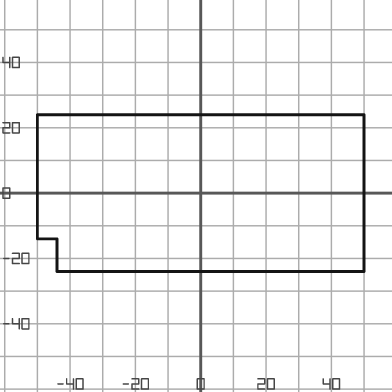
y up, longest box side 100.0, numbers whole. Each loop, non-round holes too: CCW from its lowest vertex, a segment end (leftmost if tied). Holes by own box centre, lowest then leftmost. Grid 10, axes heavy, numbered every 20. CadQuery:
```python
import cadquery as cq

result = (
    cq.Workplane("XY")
    .moveTo(-44.0, -24.0)
    .lineTo(50.0, -24.0)
    .lineTo(50.0, 24.0)
    .lineTo(-50.0, 24.0)
    .lineTo(-50.0, -14.0)
    .lineTo(-44.0, -14.0)
    .close()
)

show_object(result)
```